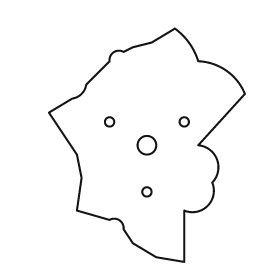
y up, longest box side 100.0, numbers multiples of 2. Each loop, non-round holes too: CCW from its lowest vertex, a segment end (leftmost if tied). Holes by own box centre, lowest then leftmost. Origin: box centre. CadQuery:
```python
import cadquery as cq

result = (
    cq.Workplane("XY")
    .moveTo(16.0, -50.0)
    .lineTo(16.0, -28.0)
    .threePointArc((26.0, -26.0), (28.0, -16.0))
    .threePointArc((30.0, -6.0), (22.0, 0.0))
    .lineTo(42.0, 22.0)
    .threePointArc((34.0, 32.0), (22.0, 36.0))
    .threePointArc((18.0, 44.0), (12.0, 50.0))
    .lineTo(2.0, 44.0)
    .lineTo(-6.0, 42.0)
    .lineTo(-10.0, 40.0)
    .threePointArc((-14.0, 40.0), (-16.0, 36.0))
    .lineTo(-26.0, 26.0)
    .threePointArc((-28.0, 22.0), (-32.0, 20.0))
    .lineTo(-42.0, 14.0)
    .lineTo(-30.0, -4.0)
    .lineTo(-28.0, -14.0)
    .lineTo(-30.0, -28.0)
    .lineTo(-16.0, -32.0)
    .threePointArc((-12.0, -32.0), (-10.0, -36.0))
    .lineTo(-6.0, -42.0)
    .lineTo(4.0, -48.0)
    .close()
    .moveTo(0.0, -20.0)
    .circle(2.0)
    .moveTo(0.0, 0.0)
    .circle(4.0)
    .moveTo(-16.0, 10.0)
    .circle(2.0)
    .moveTo(16.0, 10.0)
    .circle(2.0)
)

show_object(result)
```